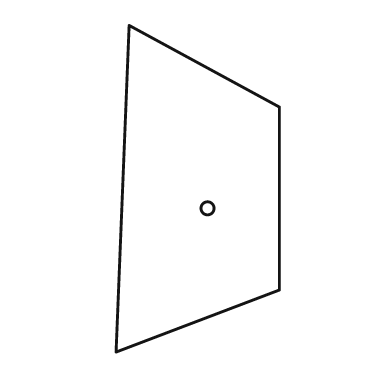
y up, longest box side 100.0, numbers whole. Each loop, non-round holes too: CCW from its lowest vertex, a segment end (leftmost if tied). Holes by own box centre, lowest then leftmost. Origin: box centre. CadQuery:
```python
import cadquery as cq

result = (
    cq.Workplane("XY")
    .moveTo(-25.0, -50.0)
    .lineTo(25.0, -31.0)
    .lineTo(25.0, 25.0)
    .lineTo(-21.0, 50.0)
    .close()
    .moveTo(3.0, -6.0)
    .circle(2.0)
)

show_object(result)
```